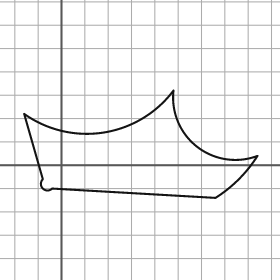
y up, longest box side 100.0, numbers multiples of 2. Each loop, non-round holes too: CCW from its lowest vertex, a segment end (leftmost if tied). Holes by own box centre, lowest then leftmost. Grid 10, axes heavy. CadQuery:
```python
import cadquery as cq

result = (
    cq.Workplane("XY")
    .moveTo(66.0, -14.0)
    .threePointArc((76.0, -6.0), (84.0, 4.0))
    .threePointArc((58.0, 8.0), (48.0, 32.0))
    .threePointArc((18.0, 14.0), (-16.0, 22.0))
    .lineTo(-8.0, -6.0)
    .threePointArc((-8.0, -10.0), (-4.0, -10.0))
    .close()
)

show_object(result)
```